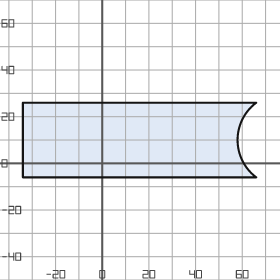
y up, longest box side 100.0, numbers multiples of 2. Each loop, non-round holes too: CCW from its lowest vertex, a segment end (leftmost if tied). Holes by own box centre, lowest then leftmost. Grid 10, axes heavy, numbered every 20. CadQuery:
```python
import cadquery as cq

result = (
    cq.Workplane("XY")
    .moveTo(-34.0, -6.0)
    .lineTo(66.0, -6.0)
    .threePointArc((58.0, 10.0), (66.0, 26.0))
    .lineTo(-34.0, 26.0)
    .close()
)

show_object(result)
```